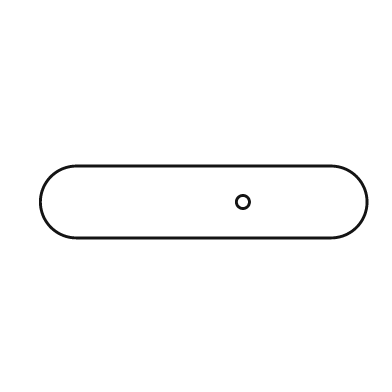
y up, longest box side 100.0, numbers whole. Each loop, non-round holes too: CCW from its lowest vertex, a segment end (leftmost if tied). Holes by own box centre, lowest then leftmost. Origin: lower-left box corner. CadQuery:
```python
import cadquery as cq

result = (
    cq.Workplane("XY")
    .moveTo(11.0, 0.0)
    .lineTo(89.0, 0.0)
    .threePointArc((100.0, 11.0), (89.0, 22.0))
    .lineTo(11.0, 22.0)
    .threePointArc((0.0, 11.0), (11.0, 0.0))
    .close()
    .moveTo(62.0, 11.0)
    .circle(2.0)
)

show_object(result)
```